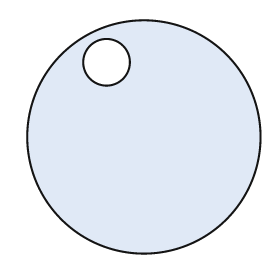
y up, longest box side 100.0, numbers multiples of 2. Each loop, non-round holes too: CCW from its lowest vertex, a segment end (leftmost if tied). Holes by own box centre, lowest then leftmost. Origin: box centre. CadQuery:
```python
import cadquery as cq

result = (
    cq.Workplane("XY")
    .moveTo(0.0, 0.0)
    .circle(50.0)
    .moveTo(-16.0, 32.0)
    .circle(10.0)
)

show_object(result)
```